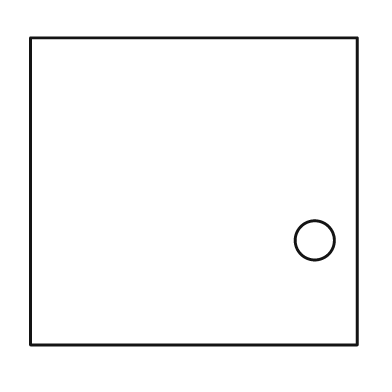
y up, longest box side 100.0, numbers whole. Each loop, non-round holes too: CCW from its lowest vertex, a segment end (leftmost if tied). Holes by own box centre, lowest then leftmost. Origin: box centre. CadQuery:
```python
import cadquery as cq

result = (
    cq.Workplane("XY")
    .moveTo(-50.0, -47.0)
    .lineTo(50.0, -47.0)
    .lineTo(50.0, 47.0)
    .lineTo(-50.0, 47.0)
    .close()
    .moveTo(37.0, -15.0)
    .circle(6.0)
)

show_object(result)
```